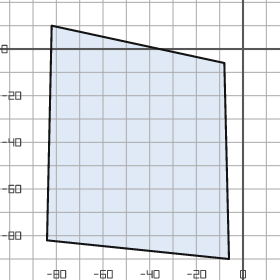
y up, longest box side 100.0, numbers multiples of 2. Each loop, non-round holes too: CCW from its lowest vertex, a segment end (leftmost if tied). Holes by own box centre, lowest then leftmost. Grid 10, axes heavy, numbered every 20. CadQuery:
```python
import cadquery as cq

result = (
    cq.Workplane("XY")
    .moveTo(-6.0, -90.0)
    .lineTo(-8.0, -6.0)
    .lineTo(-82.0, 10.0)
    .lineTo(-84.0, -82.0)
    .close()
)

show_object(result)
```